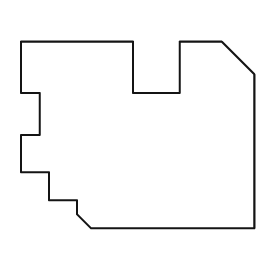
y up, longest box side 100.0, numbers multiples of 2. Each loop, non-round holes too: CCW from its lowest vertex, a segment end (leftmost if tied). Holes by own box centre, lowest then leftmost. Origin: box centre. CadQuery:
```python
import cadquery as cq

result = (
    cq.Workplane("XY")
    .moveTo(-20.0, -40.0)
    .lineTo(50.0, -40.0)
    .lineTo(50.0, 26.0)
    .lineTo(36.0, 40.0)
    .lineTo(18.0, 40.0)
    .lineTo(18.0, 18.0)
    .lineTo(-2.0, 18.0)
    .lineTo(-2.0, 40.0)
    .lineTo(-50.0, 40.0)
    .lineTo(-50.0, 18.0)
    .lineTo(-42.0, 18.0)
    .lineTo(-42.0, 0.0)
    .lineTo(-50.0, 0.0)
    .lineTo(-50.0, -16.0)
    .lineTo(-38.0, -16.0)
    .lineTo(-38.0, -28.0)
    .lineTo(-26.0, -28.0)
    .lineTo(-26.0, -34.0)
    .close()
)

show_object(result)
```